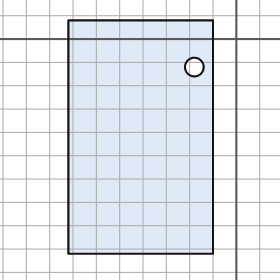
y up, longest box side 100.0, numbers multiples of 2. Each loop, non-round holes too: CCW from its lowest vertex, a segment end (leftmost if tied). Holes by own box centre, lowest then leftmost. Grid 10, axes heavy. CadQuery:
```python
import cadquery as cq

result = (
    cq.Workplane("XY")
    .moveTo(-72.0, -92.0)
    .lineTo(-10.0, -92.0)
    .lineTo(-10.0, 8.0)
    .lineTo(-72.0, 8.0)
    .close()
    .moveTo(-18.0, -12.0)
    .circle(4.0)
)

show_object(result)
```